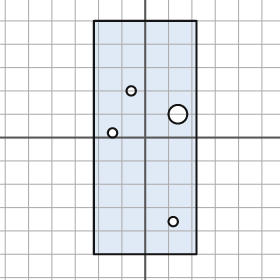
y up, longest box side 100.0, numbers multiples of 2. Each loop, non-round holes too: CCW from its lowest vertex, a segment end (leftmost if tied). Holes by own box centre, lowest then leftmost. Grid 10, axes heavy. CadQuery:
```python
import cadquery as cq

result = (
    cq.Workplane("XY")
    .moveTo(-22.0, -50.0)
    .lineTo(22.0, -50.0)
    .lineTo(22.0, 50.0)
    .lineTo(-22.0, 50.0)
    .close()
    .moveTo(12.0, -36.0)
    .circle(2.0)
    .moveTo(-14.0, 2.0)
    .circle(2.0)
    .moveTo(14.0, 10.0)
    .circle(4.0)
    .moveTo(-6.0, 20.0)
    .circle(2.0)
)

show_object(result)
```